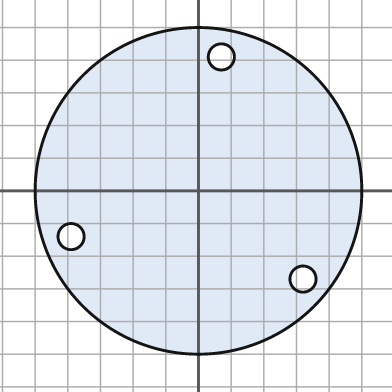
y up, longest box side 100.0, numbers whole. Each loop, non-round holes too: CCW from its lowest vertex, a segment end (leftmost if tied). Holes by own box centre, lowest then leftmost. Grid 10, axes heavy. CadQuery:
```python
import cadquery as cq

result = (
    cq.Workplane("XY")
    .moveTo(0.0, 0.0)
    .circle(50.0)
    .moveTo(32.0, -27.0)
    .circle(4.0)
    .moveTo(-39.0, -14.0)
    .circle(4.0)
    .moveTo(7.0, 41.0)
    .circle(4.0)
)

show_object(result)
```